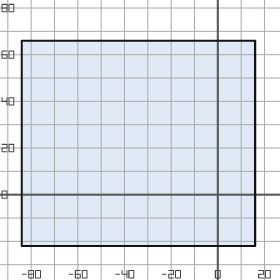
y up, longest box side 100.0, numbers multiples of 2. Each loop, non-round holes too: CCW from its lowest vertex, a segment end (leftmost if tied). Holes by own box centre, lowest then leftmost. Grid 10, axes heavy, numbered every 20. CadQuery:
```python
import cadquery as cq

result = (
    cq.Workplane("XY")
    .moveTo(-84.0, -22.0)
    .lineTo(16.0, -22.0)
    .lineTo(16.0, 66.0)
    .lineTo(-84.0, 66.0)
    .close()
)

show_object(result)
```